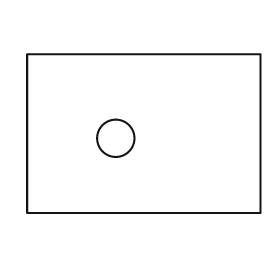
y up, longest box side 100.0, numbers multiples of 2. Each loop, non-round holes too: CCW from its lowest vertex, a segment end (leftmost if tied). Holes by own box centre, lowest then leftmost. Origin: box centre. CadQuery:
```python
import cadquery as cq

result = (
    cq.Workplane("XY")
    .moveTo(-50.0, -34.0)
    .lineTo(50.0, -34.0)
    .lineTo(50.0, 34.0)
    .lineTo(-50.0, 34.0)
    .close()
    .moveTo(-12.0, -2.0)
    .circle(8.0)
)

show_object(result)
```